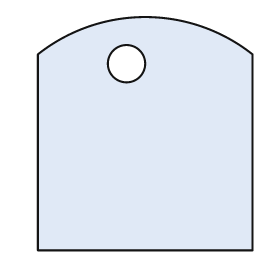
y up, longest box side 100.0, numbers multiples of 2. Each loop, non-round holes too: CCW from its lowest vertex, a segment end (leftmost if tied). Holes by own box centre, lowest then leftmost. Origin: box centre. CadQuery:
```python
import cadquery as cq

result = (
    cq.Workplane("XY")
    .moveTo(-46.0, -50.0)
    .lineTo(46.0, -50.0)
    .lineTo(46.0, 34.0)
    .threePointArc((0.0, 50.0), (-46.0, 34.0))
    .close()
    .moveTo(-8.0, 30.0)
    .circle(8.0)
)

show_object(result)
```